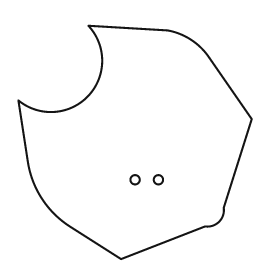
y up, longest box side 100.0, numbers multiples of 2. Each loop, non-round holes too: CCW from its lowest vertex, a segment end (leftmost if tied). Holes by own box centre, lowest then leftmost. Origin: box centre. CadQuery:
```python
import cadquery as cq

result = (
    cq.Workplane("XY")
    .moveTo(-6.0, -50.0)
    .lineTo(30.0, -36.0)
    .threePointArc((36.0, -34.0), (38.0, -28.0))
    .lineTo(50.0, 10.0)
    .lineTo(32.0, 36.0)
    .threePointArc((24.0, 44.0), (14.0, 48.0))
    .lineTo(-20.0, 50.0)
    .threePointArc((-20.0, 20.0), (-50.0, 18.0))
    .lineTo(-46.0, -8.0)
    .threePointArc((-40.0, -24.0), (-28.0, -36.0))
    .close()
    .moveTo(0.0, -16.0)
    .circle(2.0)
    .moveTo(10.0, -16.0)
    .circle(2.0)
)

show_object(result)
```